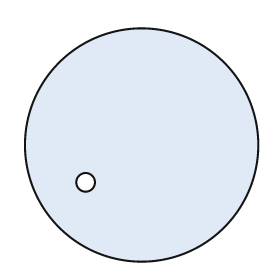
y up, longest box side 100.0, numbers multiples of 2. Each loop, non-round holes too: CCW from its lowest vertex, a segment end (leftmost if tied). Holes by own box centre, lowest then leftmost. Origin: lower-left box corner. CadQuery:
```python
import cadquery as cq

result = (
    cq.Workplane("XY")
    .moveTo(50.0, 50.0)
    .circle(50.0)
    .moveTo(26.0, 34.0)
    .circle(4.0)
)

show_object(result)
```